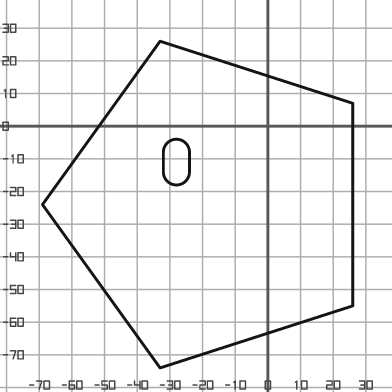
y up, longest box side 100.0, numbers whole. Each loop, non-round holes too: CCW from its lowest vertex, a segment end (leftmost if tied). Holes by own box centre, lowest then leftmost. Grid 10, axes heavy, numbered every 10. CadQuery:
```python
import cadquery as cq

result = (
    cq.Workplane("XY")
    .moveTo(-33.0, -74.0)
    .lineTo(26.0, -55.0)
    .lineTo(26.0, 7.0)
    .lineTo(-33.0, 26.0)
    .lineTo(-69.0, -24.0)
    .close()
    .moveTo(-32.0, -14.0)
    .threePointArc((-28.0, -18.0), (-24.0, -14.0))
    .lineTo(-24.0, -8.0)
    .threePointArc((-28.0, -4.0), (-32.0, -8.0))
    .close()
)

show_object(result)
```